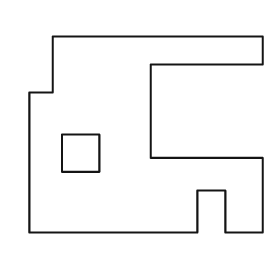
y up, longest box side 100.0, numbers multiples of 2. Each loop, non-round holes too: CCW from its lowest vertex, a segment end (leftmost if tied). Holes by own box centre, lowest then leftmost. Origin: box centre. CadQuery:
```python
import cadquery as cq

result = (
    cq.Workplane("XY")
    .moveTo(-50.0, -42.0)
    .lineTo(22.0, -42.0)
    .lineTo(22.0, -24.0)
    .lineTo(34.0, -24.0)
    .lineTo(34.0, -42.0)
    .lineTo(50.0, -42.0)
    .lineTo(50.0, -10.0)
    .lineTo(2.0, -10.0)
    .lineTo(2.0, 30.0)
    .lineTo(50.0, 30.0)
    .lineTo(50.0, 42.0)
    .lineTo(-40.0, 42.0)
    .lineTo(-40.0, 18.0)
    .lineTo(-50.0, 18.0)
    .close()
    .moveTo(-36.0, -16.0)
    .lineTo(-20.0, -16.0)
    .lineTo(-20.0, 0.0)
    .lineTo(-36.0, 0.0)
    .close()
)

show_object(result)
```